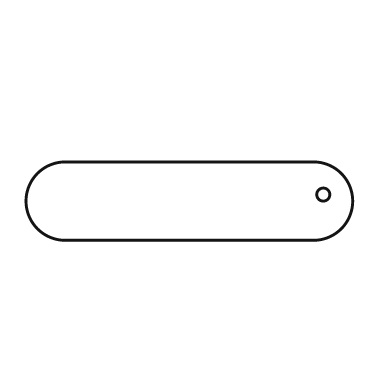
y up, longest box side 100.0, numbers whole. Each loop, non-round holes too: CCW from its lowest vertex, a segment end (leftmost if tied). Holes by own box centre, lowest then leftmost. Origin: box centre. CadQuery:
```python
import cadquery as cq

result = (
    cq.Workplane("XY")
    .moveTo(-38.0, -12.0)
    .lineTo(38.0, -12.0)
    .threePointArc((50.0, 0.0), (38.0, 12.0))
    .lineTo(-38.0, 12.0)
    .threePointArc((-50.0, 0.0), (-38.0, -12.0))
    .close()
    .moveTo(41.0, 2.0)
    .circle(2.0)
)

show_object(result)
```